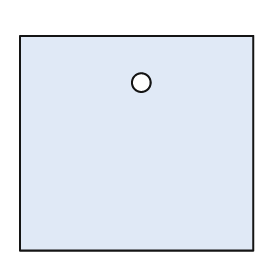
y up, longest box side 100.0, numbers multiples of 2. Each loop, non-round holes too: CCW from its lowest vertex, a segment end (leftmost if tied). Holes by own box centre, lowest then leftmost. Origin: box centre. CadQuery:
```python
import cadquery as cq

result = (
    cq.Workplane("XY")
    .moveTo(-50.0, -46.0)
    .lineTo(50.0, -46.0)
    .lineTo(50.0, 46.0)
    .lineTo(-50.0, 46.0)
    .close()
    .moveTo(2.0, 26.0)
    .circle(4.0)
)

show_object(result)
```